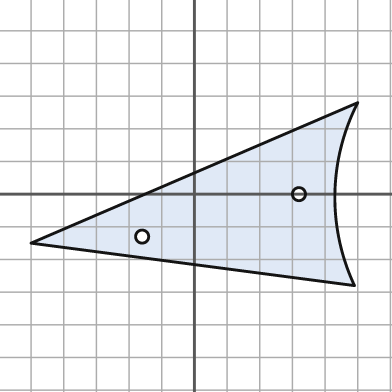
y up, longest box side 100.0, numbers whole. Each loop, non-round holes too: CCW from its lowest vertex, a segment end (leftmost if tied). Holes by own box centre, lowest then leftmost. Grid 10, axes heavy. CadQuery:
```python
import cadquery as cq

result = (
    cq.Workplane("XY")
    .moveTo(49.0, -28.0)
    .threePointArc((43.0, 0.0), (50.0, 28.0))
    .lineTo(-50.0, -15.0)
    .close()
    .moveTo(-16.0, -13.0)
    .circle(2.0)
    .moveTo(32.0, 0.0)
    .circle(2.0)
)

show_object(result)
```